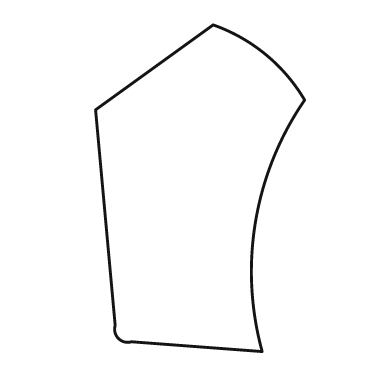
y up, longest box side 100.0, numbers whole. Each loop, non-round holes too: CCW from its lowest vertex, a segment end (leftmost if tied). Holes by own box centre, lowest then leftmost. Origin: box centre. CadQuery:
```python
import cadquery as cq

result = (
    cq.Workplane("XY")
    .moveTo(19.0, -50.0)
    .threePointArc((17.0, -10.0), (32.0, 27.0))
    .threePointArc((20.0, 41.0), (4.0, 50.0))
    .lineTo(-32.0, 24.0)
    .lineTo(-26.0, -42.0)
    .threePointArc((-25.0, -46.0), (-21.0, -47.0))
    .close()
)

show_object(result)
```